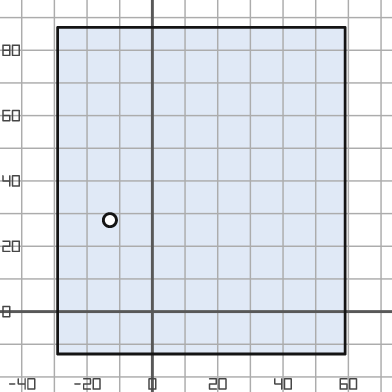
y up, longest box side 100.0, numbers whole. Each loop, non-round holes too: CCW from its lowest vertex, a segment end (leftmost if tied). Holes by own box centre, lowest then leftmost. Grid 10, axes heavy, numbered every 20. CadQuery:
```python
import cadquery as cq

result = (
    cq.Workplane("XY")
    .moveTo(-29.0, -13.0)
    .lineTo(59.0, -13.0)
    .lineTo(59.0, 87.0)
    .lineTo(-29.0, 87.0)
    .close()
    .moveTo(-13.0, 28.0)
    .circle(2.0)
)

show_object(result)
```